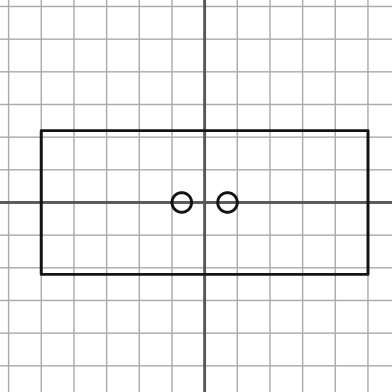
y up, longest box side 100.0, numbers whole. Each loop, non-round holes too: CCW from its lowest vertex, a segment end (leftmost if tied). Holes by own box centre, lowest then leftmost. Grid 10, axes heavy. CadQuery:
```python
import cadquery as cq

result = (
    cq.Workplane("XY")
    .moveTo(-50.0, -22.0)
    .lineTo(50.0, -22.0)
    .lineTo(50.0, 22.0)
    .lineTo(-50.0, 22.0)
    .close()
    .moveTo(-7.0, 0.0)
    .circle(3.0)
    .moveTo(7.0, 0.0)
    .circle(3.0)
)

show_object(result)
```